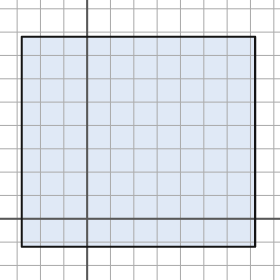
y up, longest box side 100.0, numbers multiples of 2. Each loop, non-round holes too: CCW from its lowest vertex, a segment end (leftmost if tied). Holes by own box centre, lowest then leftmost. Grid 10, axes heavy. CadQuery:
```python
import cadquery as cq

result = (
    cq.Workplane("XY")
    .moveTo(-28.0, -12.0)
    .lineTo(72.0, -12.0)
    .lineTo(72.0, 78.0)
    .lineTo(-28.0, 78.0)
    .close()
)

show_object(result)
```